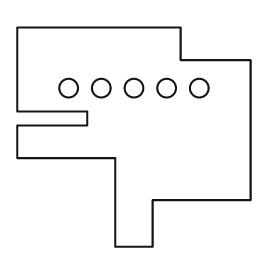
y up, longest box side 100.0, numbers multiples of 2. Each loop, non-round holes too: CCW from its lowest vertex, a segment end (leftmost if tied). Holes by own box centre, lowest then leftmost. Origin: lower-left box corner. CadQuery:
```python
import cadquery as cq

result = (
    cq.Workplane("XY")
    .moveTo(42.0, 0.0)
    .lineTo(58.0, 0.0)
    .lineTo(58.0, 20.0)
    .lineTo(100.0, 20.0)
    .lineTo(100.0, 80.0)
    .lineTo(70.0, 80.0)
    .lineTo(70.0, 94.0)
    .lineTo(0.0, 94.0)
    .lineTo(0.0, 58.0)
    .lineTo(30.0, 58.0)
    .lineTo(30.0, 52.0)
    .lineTo(0.0, 52.0)
    .lineTo(0.0, 38.0)
    .lineTo(42.0, 38.0)
    .close()
    .moveTo(22.0, 68.0)
    .circle(4.0)
    .moveTo(36.0, 68.0)
    .circle(4.0)
    .moveTo(50.0, 68.0)
    .circle(4.0)
    .moveTo(64.0, 68.0)
    .circle(4.0)
    .moveTo(78.0, 68.0)
    .circle(4.0)
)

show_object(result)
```